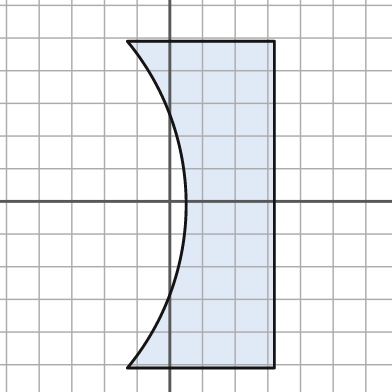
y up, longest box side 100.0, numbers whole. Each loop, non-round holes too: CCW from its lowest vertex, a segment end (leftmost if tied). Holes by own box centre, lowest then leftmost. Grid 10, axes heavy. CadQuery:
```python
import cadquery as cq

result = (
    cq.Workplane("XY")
    .moveTo(-13.0, -51.0)
    .lineTo(32.0, -51.0)
    .lineTo(32.0, 49.0)
    .lineTo(-13.0, 49.0)
    .threePointArc((5.0, -1.0), (-13.0, -51.0))
    .close()
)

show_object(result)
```